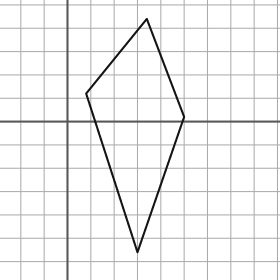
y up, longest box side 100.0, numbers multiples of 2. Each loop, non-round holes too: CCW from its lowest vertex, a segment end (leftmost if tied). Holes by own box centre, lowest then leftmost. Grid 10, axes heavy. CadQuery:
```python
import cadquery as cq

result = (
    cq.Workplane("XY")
    .moveTo(30.0, -56.0)
    .lineTo(50.0, 2.0)
    .lineTo(34.0, 44.0)
    .lineTo(8.0, 12.0)
    .close()
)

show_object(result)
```